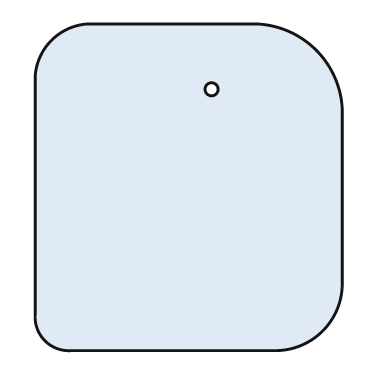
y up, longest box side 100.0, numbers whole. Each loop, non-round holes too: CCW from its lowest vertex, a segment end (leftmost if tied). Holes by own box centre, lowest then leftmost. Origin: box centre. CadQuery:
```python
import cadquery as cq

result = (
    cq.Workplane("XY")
    .moveTo(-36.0, -50.0)
    .lineTo(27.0, -50.0)
    .threePointArc((41.0, -44.0), (47.0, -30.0))
    .lineTo(47.0, 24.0)
    .threePointArc((39.0, 42.0), (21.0, 50.0))
    .lineTo(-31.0, 50.0)
    .threePointArc((-42.0, 45.0), (-47.0, 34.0))
    .lineTo(-47.0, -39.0)
    .threePointArc((-44.0, -47.0), (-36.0, -50.0))
    .close()
    .moveTo(7.0, 30.0)
    .circle(2.0)
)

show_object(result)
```